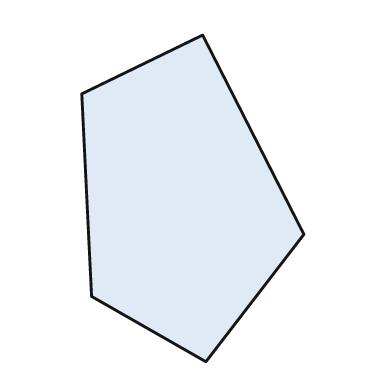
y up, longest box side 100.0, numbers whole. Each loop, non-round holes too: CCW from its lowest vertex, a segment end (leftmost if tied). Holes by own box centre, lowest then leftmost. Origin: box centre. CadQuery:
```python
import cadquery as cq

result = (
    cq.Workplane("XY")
    .moveTo(4.0, -50.0)
    .lineTo(34.0, -11.0)
    .lineTo(3.0, 50.0)
    .lineTo(-34.0, 32.0)
    .lineTo(-31.0, -30.0)
    .close()
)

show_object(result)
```